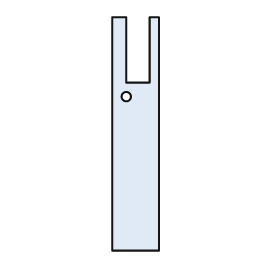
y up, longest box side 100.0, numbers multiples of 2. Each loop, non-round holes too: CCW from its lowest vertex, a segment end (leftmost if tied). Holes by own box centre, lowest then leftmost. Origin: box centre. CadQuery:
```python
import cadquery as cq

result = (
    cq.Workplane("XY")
    .moveTo(-10.0, -50.0)
    .lineTo(10.0, -50.0)
    .lineTo(10.0, 50.0)
    .lineTo(6.0, 50.0)
    .lineTo(6.0, 22.0)
    .lineTo(-4.0, 22.0)
    .lineTo(-4.0, 50.0)
    .lineTo(-10.0, 50.0)
    .close()
    .moveTo(-4.0, 16.0)
    .circle(2.0)
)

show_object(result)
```